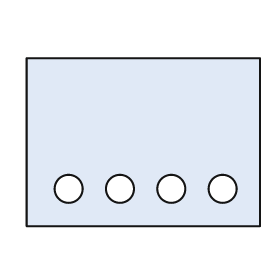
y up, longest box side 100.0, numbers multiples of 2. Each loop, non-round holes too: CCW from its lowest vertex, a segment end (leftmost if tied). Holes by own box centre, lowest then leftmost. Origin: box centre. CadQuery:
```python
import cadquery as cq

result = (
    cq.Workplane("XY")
    .moveTo(-50.0, -36.0)
    .lineTo(50.0, -36.0)
    .lineTo(50.0, 36.0)
    .lineTo(-50.0, 36.0)
    .close()
    .moveTo(-32.0, -20.0)
    .circle(6.0)
    .moveTo(-10.0, -20.0)
    .circle(6.0)
    .moveTo(12.0, -20.0)
    .circle(6.0)
    .moveTo(34.0, -20.0)
    .circle(6.0)
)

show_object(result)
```